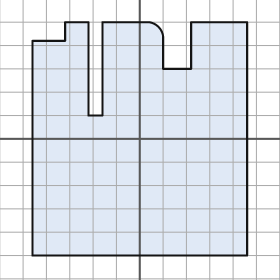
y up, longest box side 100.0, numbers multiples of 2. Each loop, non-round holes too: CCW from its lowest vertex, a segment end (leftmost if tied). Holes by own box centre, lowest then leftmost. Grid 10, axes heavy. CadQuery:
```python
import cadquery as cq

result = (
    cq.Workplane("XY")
    .moveTo(-46.0, -50.0)
    .lineTo(46.0, -50.0)
    .lineTo(46.0, 50.0)
    .lineTo(22.0, 50.0)
    .lineTo(22.0, 30.0)
    .lineTo(10.0, 30.0)
    .lineTo(10.0, 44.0)
    .threePointArc((8.0, 48.0), (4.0, 50.0))
    .lineTo(-16.0, 50.0)
    .lineTo(-16.0, 10.0)
    .lineTo(-22.0, 10.0)
    .lineTo(-22.0, 50.0)
    .lineTo(-32.0, 50.0)
    .lineTo(-32.0, 42.0)
    .lineTo(-46.0, 42.0)
    .close()
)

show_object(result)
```